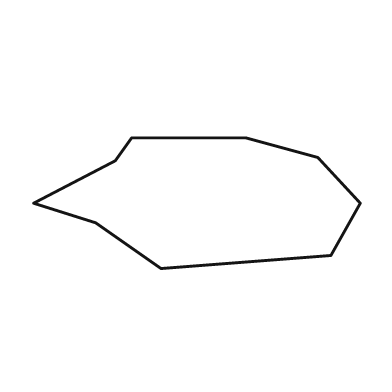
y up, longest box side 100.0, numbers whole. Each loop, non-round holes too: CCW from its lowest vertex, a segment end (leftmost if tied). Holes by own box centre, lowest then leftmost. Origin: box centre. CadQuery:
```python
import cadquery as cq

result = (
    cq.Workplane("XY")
    .moveTo(-11.0, -20.0)
    .lineTo(41.0, -16.0)
    .lineTo(50.0, 0.0)
    .lineTo(37.0, 14.0)
    .lineTo(15.0, 20.0)
    .lineTo(-20.0, 20.0)
    .lineTo(-25.0, 13.0)
    .lineTo(-50.0, 0.0)
    .lineTo(-31.0, -6.0)
    .close()
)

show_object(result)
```